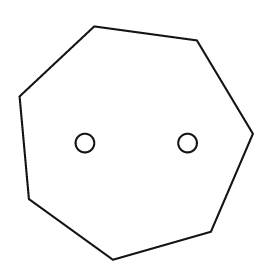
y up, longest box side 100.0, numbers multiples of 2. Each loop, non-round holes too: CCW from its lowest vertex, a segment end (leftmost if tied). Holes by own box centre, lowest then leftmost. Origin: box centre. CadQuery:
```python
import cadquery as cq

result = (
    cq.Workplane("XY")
    .moveTo(-10.0, -50.0)
    .lineTo(32.0, -38.0)
    .lineTo(50.0, 4.0)
    .lineTo(26.0, 44.0)
    .lineTo(-18.0, 50.0)
    .lineTo(-50.0, 20.0)
    .lineTo(-46.0, -24.0)
    .close()
    .moveTo(-22.0, 0.0)
    .circle(4.0)
    .moveTo(22.0, 0.0)
    .circle(4.0)
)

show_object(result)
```